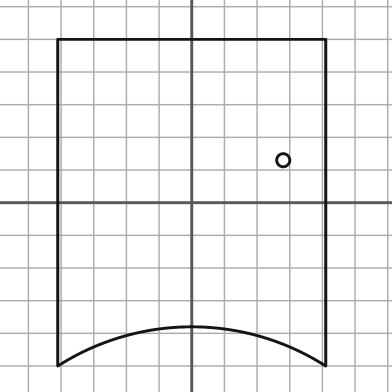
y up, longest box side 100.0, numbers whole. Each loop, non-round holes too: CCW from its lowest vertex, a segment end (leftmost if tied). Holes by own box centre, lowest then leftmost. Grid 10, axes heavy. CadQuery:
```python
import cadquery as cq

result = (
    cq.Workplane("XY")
    .moveTo(-41.0, -50.0)
    .threePointArc((0.0, -38.0), (41.0, -50.0))
    .lineTo(41.0, 50.0)
    .lineTo(-41.0, 50.0)
    .close()
    .moveTo(28.0, 13.0)
    .circle(2.0)
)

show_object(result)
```